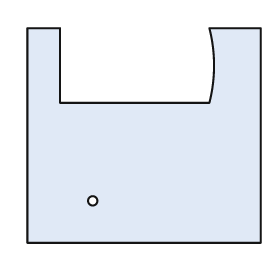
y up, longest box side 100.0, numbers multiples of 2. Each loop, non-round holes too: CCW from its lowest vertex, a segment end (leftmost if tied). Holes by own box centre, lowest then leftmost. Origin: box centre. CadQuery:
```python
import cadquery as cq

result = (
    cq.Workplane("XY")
    .moveTo(-50.0, -46.0)
    .lineTo(50.0, -46.0)
    .lineTo(50.0, 46.0)
    .lineTo(28.0, 46.0)
    .threePointArc((30.0, 30.0), (28.0, 14.0))
    .lineTo(-36.0, 14.0)
    .lineTo(-36.0, 46.0)
    .lineTo(-50.0, 46.0)
    .close()
    .moveTo(-22.0, -28.0)
    .circle(2.0)
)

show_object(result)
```